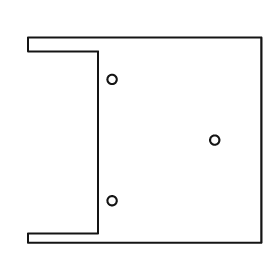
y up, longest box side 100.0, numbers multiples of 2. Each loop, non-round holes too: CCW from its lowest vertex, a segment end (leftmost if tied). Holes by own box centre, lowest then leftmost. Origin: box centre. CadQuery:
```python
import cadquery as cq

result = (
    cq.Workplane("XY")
    .moveTo(-50.0, -44.0)
    .lineTo(50.0, -44.0)
    .lineTo(50.0, 44.0)
    .lineTo(-50.0, 44.0)
    .lineTo(-50.0, 38.0)
    .lineTo(-20.0, 38.0)
    .lineTo(-20.0, -40.0)
    .lineTo(-50.0, -40.0)
    .close()
    .moveTo(-14.0, -26.0)
    .circle(2.0)
    .moveTo(30.0, 0.0)
    .circle(2.0)
    .moveTo(-14.0, 26.0)
    .circle(2.0)
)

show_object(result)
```